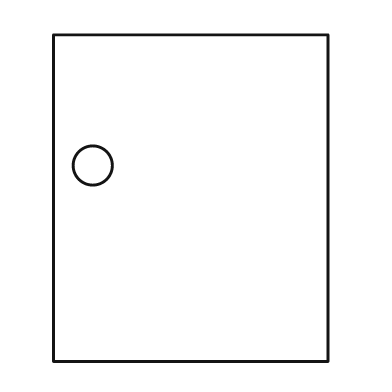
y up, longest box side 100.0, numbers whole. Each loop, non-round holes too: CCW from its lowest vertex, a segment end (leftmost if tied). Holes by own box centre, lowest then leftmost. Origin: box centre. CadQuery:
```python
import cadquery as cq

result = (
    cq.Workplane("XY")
    .moveTo(-42.0, -50.0)
    .lineTo(42.0, -50.0)
    .lineTo(42.0, 50.0)
    .lineTo(-42.0, 50.0)
    .close()
    .moveTo(-30.0, 10.0)
    .circle(6.0)
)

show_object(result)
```